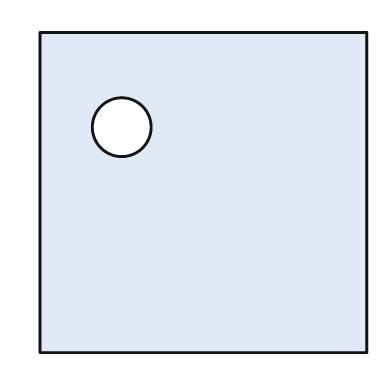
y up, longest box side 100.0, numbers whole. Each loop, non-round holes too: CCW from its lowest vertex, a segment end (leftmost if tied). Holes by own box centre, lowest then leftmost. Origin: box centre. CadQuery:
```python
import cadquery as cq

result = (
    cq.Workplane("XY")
    .moveTo(-50.0, -49.0)
    .lineTo(50.0, -49.0)
    .lineTo(50.0, 49.0)
    .lineTo(-50.0, 49.0)
    .close()
    .moveTo(-25.0, 20.0)
    .circle(9.0)
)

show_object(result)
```